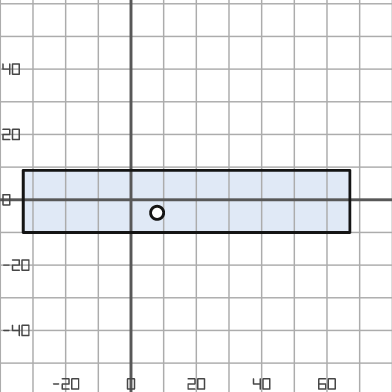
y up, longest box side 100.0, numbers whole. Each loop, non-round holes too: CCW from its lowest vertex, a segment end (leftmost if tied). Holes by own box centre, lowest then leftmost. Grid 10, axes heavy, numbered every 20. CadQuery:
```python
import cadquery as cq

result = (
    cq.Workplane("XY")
    .moveTo(-33.0, -10.0)
    .lineTo(67.0, -10.0)
    .lineTo(67.0, 9.0)
    .lineTo(-33.0, 9.0)
    .close()
    .moveTo(8.0, -4.0)
    .circle(2.0)
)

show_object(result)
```